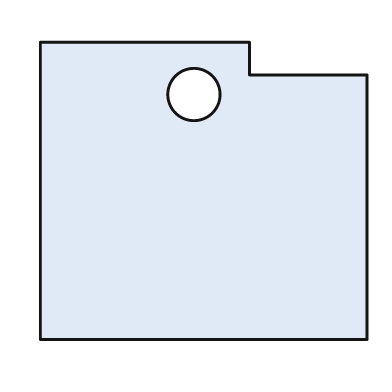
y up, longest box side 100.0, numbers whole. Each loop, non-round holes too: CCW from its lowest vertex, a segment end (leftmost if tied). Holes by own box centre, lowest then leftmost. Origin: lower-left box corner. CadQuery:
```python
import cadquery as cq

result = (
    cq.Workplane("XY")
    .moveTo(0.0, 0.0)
    .lineTo(100.0, 0.0)
    .lineTo(100.0, 81.0)
    .lineTo(64.0, 81.0)
    .lineTo(64.0, 91.0)
    .lineTo(0.0, 91.0)
    .close()
    .moveTo(47.0, 75.0)
    .circle(8.0)
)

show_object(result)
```